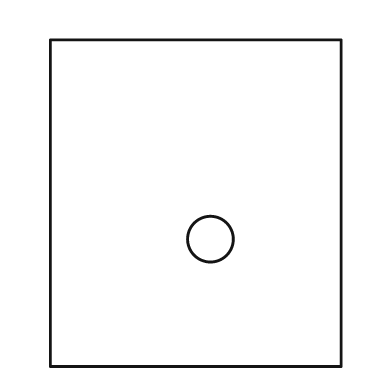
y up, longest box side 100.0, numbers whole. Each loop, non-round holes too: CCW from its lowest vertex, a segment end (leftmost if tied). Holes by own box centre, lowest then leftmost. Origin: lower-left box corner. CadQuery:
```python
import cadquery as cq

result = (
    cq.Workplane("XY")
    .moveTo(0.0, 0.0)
    .lineTo(89.0, 0.0)
    .lineTo(89.0, 100.0)
    .lineTo(0.0, 100.0)
    .close()
    .moveTo(49.0, 39.0)
    .circle(7.0)
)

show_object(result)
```